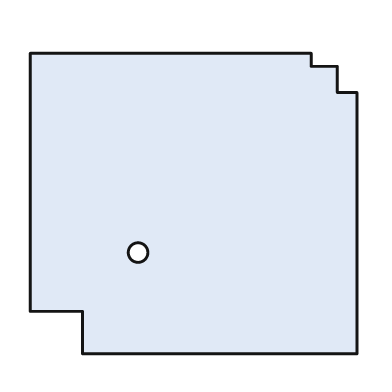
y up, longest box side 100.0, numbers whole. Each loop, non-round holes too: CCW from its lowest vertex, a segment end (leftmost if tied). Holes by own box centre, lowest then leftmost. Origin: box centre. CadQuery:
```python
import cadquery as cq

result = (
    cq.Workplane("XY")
    .moveTo(-34.0, -46.0)
    .lineTo(50.0, -46.0)
    .lineTo(50.0, 34.0)
    .lineTo(44.0, 34.0)
    .lineTo(44.0, 42.0)
    .lineTo(36.0, 42.0)
    .lineTo(36.0, 46.0)
    .lineTo(-50.0, 46.0)
    .lineTo(-50.0, -33.0)
    .lineTo(-34.0, -33.0)
    .close()
    .moveTo(-17.0, -15.0)
    .circle(3.0)
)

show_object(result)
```